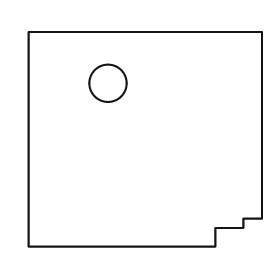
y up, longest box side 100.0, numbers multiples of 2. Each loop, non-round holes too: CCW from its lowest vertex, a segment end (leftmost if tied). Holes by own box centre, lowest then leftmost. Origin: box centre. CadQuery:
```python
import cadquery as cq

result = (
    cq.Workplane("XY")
    .moveTo(-50.0, -46.0)
    .lineTo(30.0, -46.0)
    .lineTo(30.0, -38.0)
    .lineTo(42.0, -38.0)
    .lineTo(42.0, -34.0)
    .lineTo(50.0, -34.0)
    .lineTo(50.0, 46.0)
    .lineTo(-50.0, 46.0)
    .close()
    .moveTo(-16.0, 24.0)
    .circle(8.0)
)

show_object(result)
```